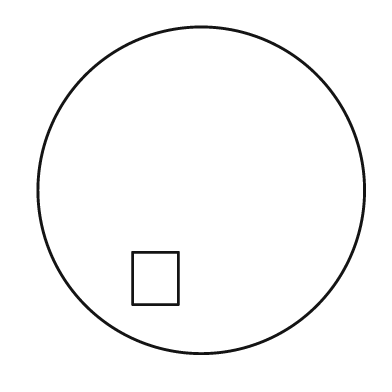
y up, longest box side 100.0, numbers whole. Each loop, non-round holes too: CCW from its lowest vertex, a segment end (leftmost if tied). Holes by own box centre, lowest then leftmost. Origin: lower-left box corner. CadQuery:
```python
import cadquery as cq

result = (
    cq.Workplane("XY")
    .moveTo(50.0, 50.0)
    .circle(50.0)
    .moveTo(29.0, 15.0)
    .lineTo(43.0, 15.0)
    .lineTo(43.0, 31.0)
    .lineTo(29.0, 31.0)
    .close()
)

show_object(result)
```